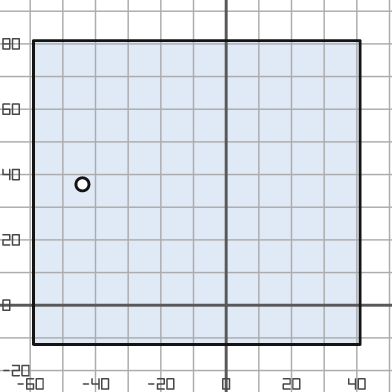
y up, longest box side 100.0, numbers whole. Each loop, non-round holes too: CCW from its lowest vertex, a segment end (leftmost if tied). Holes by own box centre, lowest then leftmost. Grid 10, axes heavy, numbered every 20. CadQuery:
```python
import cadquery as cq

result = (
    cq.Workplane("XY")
    .moveTo(-59.0, -12.0)
    .lineTo(41.0, -12.0)
    .lineTo(41.0, 81.0)
    .lineTo(-59.0, 81.0)
    .close()
    .moveTo(-44.0, 37.0)
    .circle(2.0)
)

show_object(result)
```